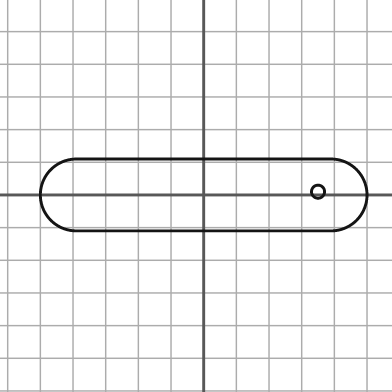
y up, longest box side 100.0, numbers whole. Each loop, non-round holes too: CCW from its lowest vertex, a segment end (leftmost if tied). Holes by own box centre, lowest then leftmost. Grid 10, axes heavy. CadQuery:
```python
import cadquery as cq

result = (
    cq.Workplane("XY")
    .moveTo(-39.0, -11.0)
    .lineTo(39.0, -11.0)
    .threePointArc((50.0, 0.0), (39.0, 11.0))
    .lineTo(-39.0, 11.0)
    .threePointArc((-50.0, 0.0), (-39.0, -11.0))
    .close()
    .moveTo(35.0, 1.0)
    .circle(2.0)
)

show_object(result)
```